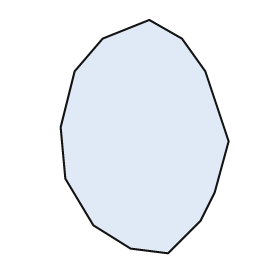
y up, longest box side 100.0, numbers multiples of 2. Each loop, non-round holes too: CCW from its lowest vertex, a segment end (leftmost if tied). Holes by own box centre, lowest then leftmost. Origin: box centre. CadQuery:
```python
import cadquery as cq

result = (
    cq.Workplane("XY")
    .moveTo(10.0, -50.0)
    .lineTo(24.0, -36.0)
    .lineTo(30.0, -24.0)
    .lineTo(36.0, -2.0)
    .lineTo(26.0, 28.0)
    .lineTo(16.0, 42.0)
    .lineTo(2.0, 50.0)
    .lineTo(-18.0, 42.0)
    .lineTo(-30.0, 28.0)
    .lineTo(-36.0, 4.0)
    .lineTo(-34.0, -18.0)
    .lineTo(-22.0, -38.0)
    .lineTo(-6.0, -48.0)
    .close()
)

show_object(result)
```